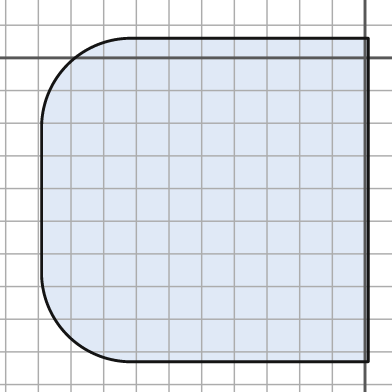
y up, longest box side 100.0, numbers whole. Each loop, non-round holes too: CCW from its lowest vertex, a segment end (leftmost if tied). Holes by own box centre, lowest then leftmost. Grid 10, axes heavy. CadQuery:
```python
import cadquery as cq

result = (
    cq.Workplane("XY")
    .moveTo(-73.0, -93.0)
    .lineTo(1.0, -93.0)
    .lineTo(1.0, 6.0)
    .lineTo(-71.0, 6.0)
    .threePointArc((-91.0, -2.0), (-99.0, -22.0))
    .lineTo(-99.0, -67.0)
    .threePointArc((-91.0, -85.0), (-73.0, -93.0))
    .close()
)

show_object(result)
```